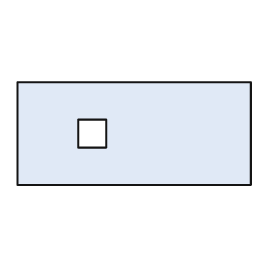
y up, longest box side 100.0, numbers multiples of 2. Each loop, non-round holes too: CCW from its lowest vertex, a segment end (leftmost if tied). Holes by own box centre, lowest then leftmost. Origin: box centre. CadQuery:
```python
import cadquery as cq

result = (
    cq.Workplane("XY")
    .moveTo(-50.0, -22.0)
    .lineTo(50.0, -22.0)
    .lineTo(50.0, 22.0)
    .lineTo(-50.0, 22.0)
    .close()
    .moveTo(-24.0, -6.0)
    .lineTo(-12.0, -6.0)
    .lineTo(-12.0, 6.0)
    .lineTo(-24.0, 6.0)
    .close()
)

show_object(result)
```